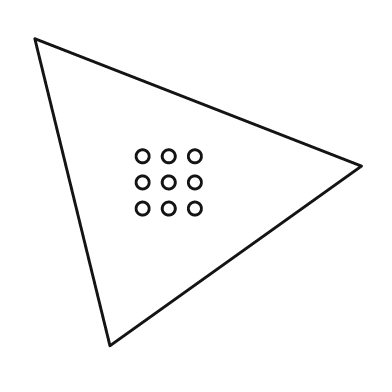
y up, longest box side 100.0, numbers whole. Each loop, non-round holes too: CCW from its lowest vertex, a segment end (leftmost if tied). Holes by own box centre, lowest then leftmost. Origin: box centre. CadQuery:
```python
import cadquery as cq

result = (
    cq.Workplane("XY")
    .moveTo(-27.0, -47.0)
    .lineTo(50.0, 8.0)
    .lineTo(-50.0, 47.0)
    .close()
    .moveTo(-17.0, -5.0)
    .circle(2.0)
    .moveTo(-9.0, -5.0)
    .circle(2.0)
    .moveTo(-1.0, -5.0)
    .circle(2.0)
    .moveTo(-17.0, 3.0)
    .circle(2.0)
    .moveTo(-9.0, 3.0)
    .circle(2.0)
    .moveTo(-1.0, 3.0)
    .circle(2.0)
    .moveTo(-17.0, 11.0)
    .circle(2.0)
    .moveTo(-9.0, 11.0)
    .circle(2.0)
    .moveTo(-1.0, 11.0)
    .circle(2.0)
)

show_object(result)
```